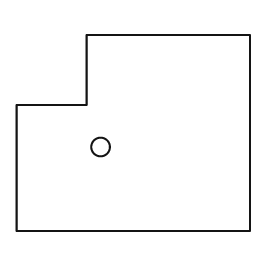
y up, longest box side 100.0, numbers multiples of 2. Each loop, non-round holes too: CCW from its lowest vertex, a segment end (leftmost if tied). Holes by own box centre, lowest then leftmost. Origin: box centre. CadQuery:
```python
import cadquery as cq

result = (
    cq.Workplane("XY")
    .moveTo(-50.0, -42.0)
    .lineTo(50.0, -42.0)
    .lineTo(50.0, 42.0)
    .lineTo(-20.0, 42.0)
    .lineTo(-20.0, 12.0)
    .lineTo(-50.0, 12.0)
    .close()
    .moveTo(-14.0, -6.0)
    .circle(4.0)
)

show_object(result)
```